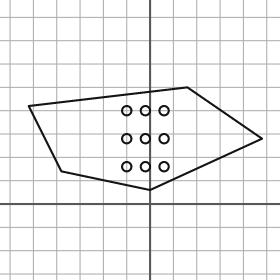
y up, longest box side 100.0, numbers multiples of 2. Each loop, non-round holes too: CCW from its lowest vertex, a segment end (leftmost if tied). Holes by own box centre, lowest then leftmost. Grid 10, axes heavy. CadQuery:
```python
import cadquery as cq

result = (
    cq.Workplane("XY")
    .moveTo(0.0, 6.0)
    .lineTo(48.0, 28.0)
    .lineTo(16.0, 50.0)
    .lineTo(-52.0, 42.0)
    .lineTo(-38.0, 14.0)
    .close()
    .moveTo(-10.0, 16.0)
    .circle(2.0)
    .moveTo(-2.0, 16.0)
    .circle(2.0)
    .moveTo(6.0, 16.0)
    .circle(2.0)
    .moveTo(-10.0, 28.0)
    .circle(2.0)
    .moveTo(-2.0, 28.0)
    .circle(2.0)
    .moveTo(6.0, 28.0)
    .circle(2.0)
    .moveTo(-10.0, 40.0)
    .circle(2.0)
    .moveTo(-2.0, 40.0)
    .circle(2.0)
    .moveTo(6.0, 40.0)
    .circle(2.0)
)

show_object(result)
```